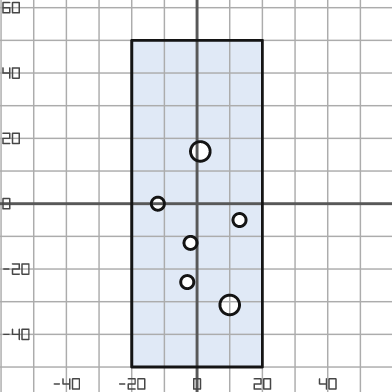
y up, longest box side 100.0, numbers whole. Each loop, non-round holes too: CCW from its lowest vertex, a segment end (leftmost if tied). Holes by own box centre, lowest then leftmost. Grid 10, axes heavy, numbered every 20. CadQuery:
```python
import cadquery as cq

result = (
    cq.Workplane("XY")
    .moveTo(-20.0, -50.0)
    .lineTo(20.0, -50.0)
    .lineTo(20.0, 50.0)
    .lineTo(-20.0, 50.0)
    .close()
    .moveTo(10.0, -31.0)
    .circle(3.0)
    .moveTo(-3.0, -24.0)
    .circle(2.0)
    .moveTo(-2.0, -12.0)
    .circle(2.0)
    .moveTo(13.0, -5.0)
    .circle(2.0)
    .moveTo(-12.0, 0.0)
    .circle(2.0)
    .moveTo(1.0, 16.0)
    .circle(3.0)
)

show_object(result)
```